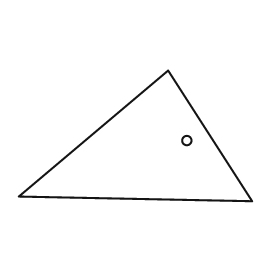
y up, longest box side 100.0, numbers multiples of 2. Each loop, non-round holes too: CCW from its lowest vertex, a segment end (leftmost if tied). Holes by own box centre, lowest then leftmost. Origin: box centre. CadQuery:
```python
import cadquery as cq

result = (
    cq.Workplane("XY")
    .moveTo(50.0, -28.0)
    .lineTo(14.0, 28.0)
    .lineTo(-50.0, -26.0)
    .close()
    .moveTo(22.0, -2.0)
    .circle(2.0)
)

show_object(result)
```